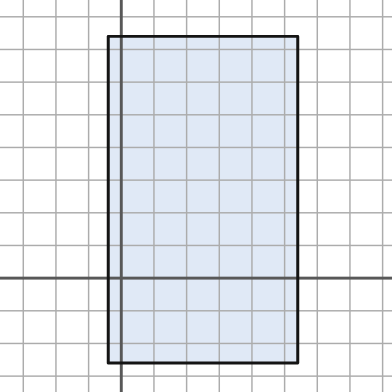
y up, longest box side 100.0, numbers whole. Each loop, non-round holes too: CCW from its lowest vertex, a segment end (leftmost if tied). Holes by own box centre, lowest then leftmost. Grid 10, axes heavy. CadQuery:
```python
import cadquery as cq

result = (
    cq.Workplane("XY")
    .moveTo(-4.0, -26.0)
    .lineTo(54.0, -26.0)
    .lineTo(54.0, 74.0)
    .lineTo(-4.0, 74.0)
    .close()
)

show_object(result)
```